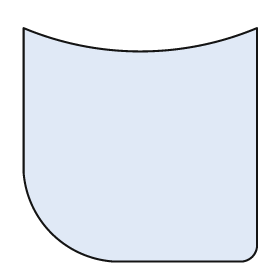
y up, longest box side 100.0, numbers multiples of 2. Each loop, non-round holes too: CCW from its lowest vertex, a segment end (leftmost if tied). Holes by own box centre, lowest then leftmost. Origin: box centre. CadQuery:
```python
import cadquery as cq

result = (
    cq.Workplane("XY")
    .moveTo(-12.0, -50.0)
    .lineTo(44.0, -50.0)
    .threePointArc((48.0, -48.0), (50.0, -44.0))
    .lineTo(50.0, 50.0)
    .threePointArc((0.0, 40.0), (-50.0, 50.0))
    .lineTo(-50.0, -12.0)
    .threePointArc((-38.0, -38.0), (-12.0, -50.0))
    .close()
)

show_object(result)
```